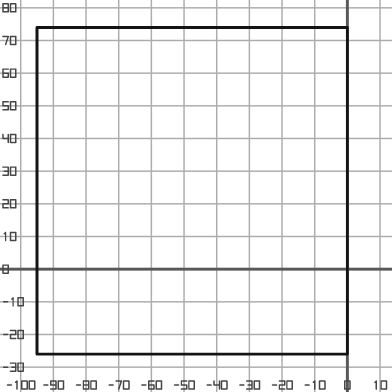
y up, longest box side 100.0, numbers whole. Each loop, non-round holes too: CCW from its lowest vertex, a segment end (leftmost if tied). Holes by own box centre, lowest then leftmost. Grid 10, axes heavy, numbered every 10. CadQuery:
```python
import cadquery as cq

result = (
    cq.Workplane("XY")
    .moveTo(-95.0, -26.0)
    .lineTo(0.0, -26.0)
    .lineTo(0.0, 74.0)
    .lineTo(-95.0, 74.0)
    .close()
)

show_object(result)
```